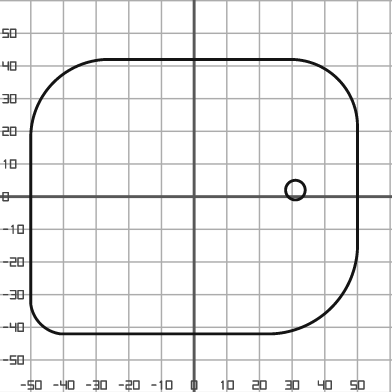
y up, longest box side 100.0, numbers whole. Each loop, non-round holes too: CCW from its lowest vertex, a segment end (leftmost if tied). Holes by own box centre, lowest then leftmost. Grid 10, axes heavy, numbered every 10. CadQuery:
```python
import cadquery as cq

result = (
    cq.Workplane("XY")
    .moveTo(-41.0, -42.0)
    .lineTo(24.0, -42.0)
    .threePointArc((42.0, -34.0), (50.0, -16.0))
    .lineTo(50.0, 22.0)
    .threePointArc((44.0, 36.0), (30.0, 42.0))
    .lineTo(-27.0, 42.0)
    .threePointArc((-43.0, 35.0), (-50.0, 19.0))
    .lineTo(-50.0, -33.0)
    .threePointArc((-47.0, -39.0), (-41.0, -42.0))
    .close()
    .moveTo(31.0, 2.0)
    .circle(3.0)
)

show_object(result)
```